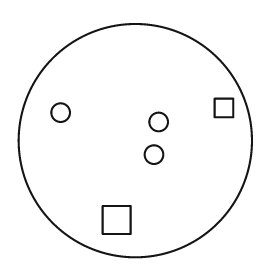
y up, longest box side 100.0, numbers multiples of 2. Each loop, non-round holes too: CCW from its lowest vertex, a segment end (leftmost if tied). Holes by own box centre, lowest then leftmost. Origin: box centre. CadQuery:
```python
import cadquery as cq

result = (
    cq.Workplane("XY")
    .moveTo(0.0, 0.0)
    .circle(50.0)
    .moveTo(-14.0, -40.0)
    .lineTo(-2.0, -40.0)
    .lineTo(-2.0, -28.0)
    .lineTo(-14.0, -28.0)
    .close()
    .moveTo(8.0, -6.0)
    .circle(4.0)
    .moveTo(10.0, 8.0)
    .circle(4.0)
    .moveTo(-32.0, 12.0)
    .circle(4.0)
    .moveTo(34.0, 10.0)
    .lineTo(42.0, 10.0)
    .lineTo(42.0, 18.0)
    .lineTo(34.0, 18.0)
    .close()
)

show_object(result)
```